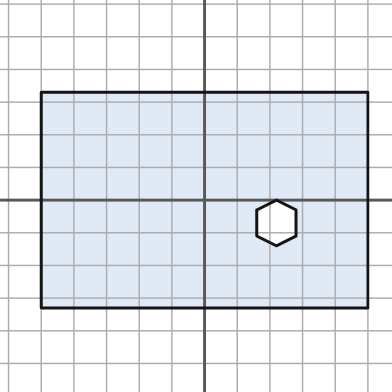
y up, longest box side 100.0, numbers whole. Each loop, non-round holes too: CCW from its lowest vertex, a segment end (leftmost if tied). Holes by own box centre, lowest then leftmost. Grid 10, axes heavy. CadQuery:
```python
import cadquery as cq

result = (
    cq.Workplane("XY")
    .moveTo(-50.0, -33.0)
    .lineTo(50.0, -33.0)
    .lineTo(50.0, 33.0)
    .lineTo(-50.0, 33.0)
    .close()
    .moveTo(22.0, -14.0)
    .lineTo(28.0, -11.0)
    .lineTo(28.0, -3.0)
    .lineTo(22.0, 0.0)
    .lineTo(16.0, -3.0)
    .lineTo(16.0, -11.0)
    .close()
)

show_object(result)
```